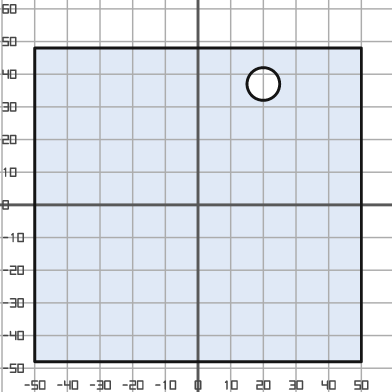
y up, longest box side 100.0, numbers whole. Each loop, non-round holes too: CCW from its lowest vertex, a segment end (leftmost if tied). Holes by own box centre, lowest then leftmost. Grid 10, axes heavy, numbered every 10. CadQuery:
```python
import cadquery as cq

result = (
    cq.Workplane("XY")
    .moveTo(-50.0, -48.0)
    .lineTo(50.0, -48.0)
    .lineTo(50.0, 48.0)
    .lineTo(-50.0, 48.0)
    .close()
    .moveTo(20.0, 37.0)
    .circle(5.0)
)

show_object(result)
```